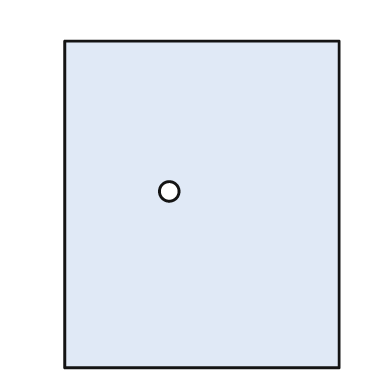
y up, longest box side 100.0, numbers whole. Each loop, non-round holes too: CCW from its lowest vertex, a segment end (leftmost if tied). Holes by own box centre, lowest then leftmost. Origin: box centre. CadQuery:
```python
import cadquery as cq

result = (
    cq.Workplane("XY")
    .moveTo(-42.0, -50.0)
    .lineTo(42.0, -50.0)
    .lineTo(42.0, 50.0)
    .lineTo(-42.0, 50.0)
    .close()
    .moveTo(-10.0, 4.0)
    .circle(3.0)
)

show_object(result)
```